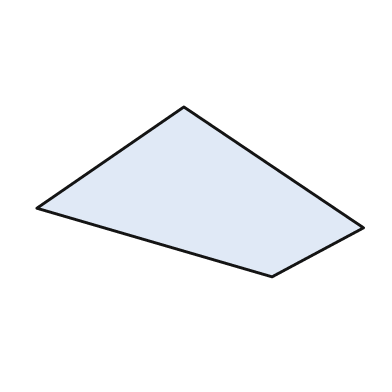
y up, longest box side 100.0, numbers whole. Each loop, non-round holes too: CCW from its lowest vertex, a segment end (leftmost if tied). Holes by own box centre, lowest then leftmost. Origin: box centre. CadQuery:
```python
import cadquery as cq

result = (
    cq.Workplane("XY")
    .moveTo(22.0, -26.0)
    .lineTo(50.0, -11.0)
    .lineTo(-5.0, 26.0)
    .lineTo(-50.0, -5.0)
    .close()
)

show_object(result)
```